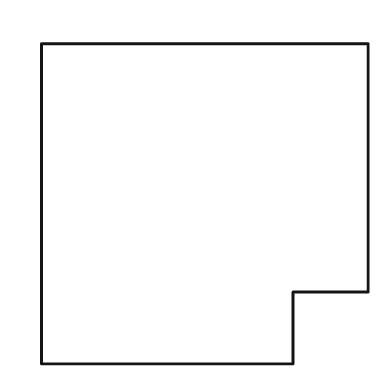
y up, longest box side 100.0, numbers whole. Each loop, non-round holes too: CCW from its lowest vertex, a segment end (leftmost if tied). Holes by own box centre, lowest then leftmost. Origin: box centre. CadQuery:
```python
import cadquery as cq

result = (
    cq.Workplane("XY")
    .moveTo(-50.0, -49.0)
    .lineTo(27.0, -49.0)
    .lineTo(27.0, -27.0)
    .lineTo(50.0, -27.0)
    .lineTo(50.0, 49.0)
    .lineTo(-50.0, 49.0)
    .close()
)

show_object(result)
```